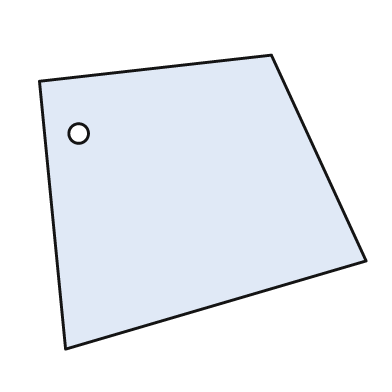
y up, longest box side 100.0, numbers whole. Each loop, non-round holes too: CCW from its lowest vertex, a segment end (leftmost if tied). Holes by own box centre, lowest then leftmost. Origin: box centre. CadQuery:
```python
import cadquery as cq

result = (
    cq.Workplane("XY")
    .moveTo(-42.0, -45.0)
    .lineTo(50.0, -18.0)
    .lineTo(21.0, 45.0)
    .lineTo(-50.0, 37.0)
    .close()
    .moveTo(-38.0, 21.0)
    .circle(3.0)
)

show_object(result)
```